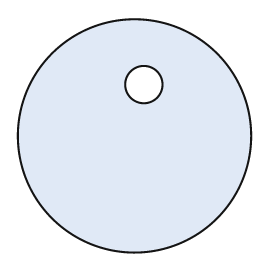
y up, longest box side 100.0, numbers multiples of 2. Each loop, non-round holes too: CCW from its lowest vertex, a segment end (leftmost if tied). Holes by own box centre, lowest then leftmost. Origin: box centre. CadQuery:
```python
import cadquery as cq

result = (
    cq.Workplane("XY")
    .moveTo(0.0, 0.0)
    .circle(50.0)
    .moveTo(4.0, 22.0)
    .circle(8.0)
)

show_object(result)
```